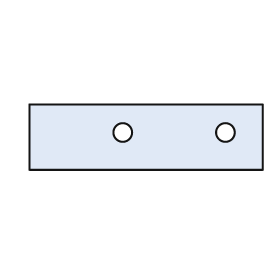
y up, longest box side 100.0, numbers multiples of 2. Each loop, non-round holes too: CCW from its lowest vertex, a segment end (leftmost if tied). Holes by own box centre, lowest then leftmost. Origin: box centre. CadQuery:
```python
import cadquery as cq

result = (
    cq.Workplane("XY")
    .moveTo(-50.0, -14.0)
    .lineTo(50.0, -14.0)
    .lineTo(50.0, 14.0)
    .lineTo(-50.0, 14.0)
    .close()
    .moveTo(-10.0, 2.0)
    .circle(4.0)
    .moveTo(34.0, 2.0)
    .circle(4.0)
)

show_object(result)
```